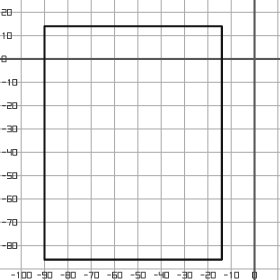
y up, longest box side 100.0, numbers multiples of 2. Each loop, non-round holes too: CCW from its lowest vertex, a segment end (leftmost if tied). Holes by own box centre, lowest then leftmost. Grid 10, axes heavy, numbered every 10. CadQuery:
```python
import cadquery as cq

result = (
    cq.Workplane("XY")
    .moveTo(-90.0, -86.0)
    .lineTo(-14.0, -86.0)
    .lineTo(-14.0, 14.0)
    .lineTo(-90.0, 14.0)
    .close()
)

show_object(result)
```